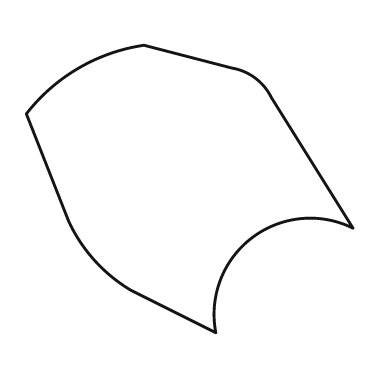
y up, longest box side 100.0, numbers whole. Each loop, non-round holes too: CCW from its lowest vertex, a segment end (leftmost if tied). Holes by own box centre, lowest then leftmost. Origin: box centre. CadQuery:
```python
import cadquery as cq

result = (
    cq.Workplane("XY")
    .moveTo(8.0, -44.0)
    .threePointArc((19.0, -15.0), (50.0, -12.0))
    .lineTo(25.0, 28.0)
    .threePointArc((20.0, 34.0), (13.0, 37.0))
    .lineTo(-14.0, 44.0)
    .threePointArc((-34.0, 37.0), (-50.0, 23.0))
    .lineTo(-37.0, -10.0)
    .threePointArc((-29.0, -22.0), (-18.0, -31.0))
    .close()
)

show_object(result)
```